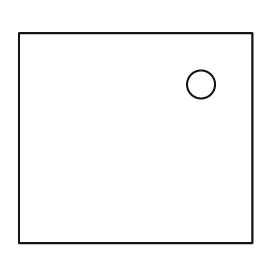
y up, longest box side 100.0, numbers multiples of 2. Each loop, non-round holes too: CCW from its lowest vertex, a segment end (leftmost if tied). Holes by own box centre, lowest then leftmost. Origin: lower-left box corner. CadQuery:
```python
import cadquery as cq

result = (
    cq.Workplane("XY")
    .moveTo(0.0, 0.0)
    .lineTo(100.0, 0.0)
    .lineTo(100.0, 90.0)
    .lineTo(0.0, 90.0)
    .close()
    .moveTo(78.0, 68.0)
    .circle(6.0)
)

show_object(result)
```